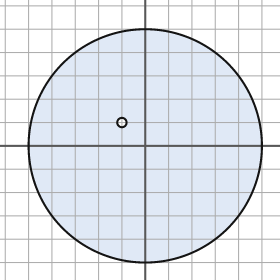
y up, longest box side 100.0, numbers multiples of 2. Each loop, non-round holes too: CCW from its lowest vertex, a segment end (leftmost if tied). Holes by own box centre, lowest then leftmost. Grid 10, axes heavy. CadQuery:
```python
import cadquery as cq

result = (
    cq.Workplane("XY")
    .moveTo(0.0, 0.0)
    .circle(50.0)
    .moveTo(-10.0, 10.0)
    .circle(2.0)
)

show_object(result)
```